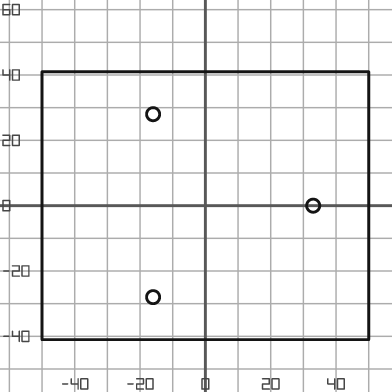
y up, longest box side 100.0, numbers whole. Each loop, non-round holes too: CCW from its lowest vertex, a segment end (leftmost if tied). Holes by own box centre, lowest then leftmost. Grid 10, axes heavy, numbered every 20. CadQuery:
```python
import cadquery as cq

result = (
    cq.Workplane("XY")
    .moveTo(-50.0, -41.0)
    .lineTo(50.0, -41.0)
    .lineTo(50.0, 41.0)
    .lineTo(-50.0, 41.0)
    .close()
    .moveTo(-16.0, -28.0)
    .circle(2.0)
    .moveTo(33.0, 0.0)
    .circle(2.0)
    .moveTo(-16.0, 28.0)
    .circle(2.0)
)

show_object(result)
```